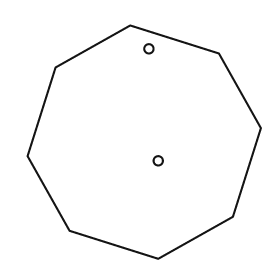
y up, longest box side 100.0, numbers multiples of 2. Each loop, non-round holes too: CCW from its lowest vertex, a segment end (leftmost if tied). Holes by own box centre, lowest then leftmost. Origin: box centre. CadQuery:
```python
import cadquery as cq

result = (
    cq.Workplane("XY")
    .moveTo(6.0, -50.0)
    .lineTo(38.0, -32.0)
    .lineTo(50.0, 6.0)
    .lineTo(32.0, 38.0)
    .lineTo(-6.0, 50.0)
    .lineTo(-38.0, 32.0)
    .lineTo(-50.0, -6.0)
    .lineTo(-32.0, -38.0)
    .close()
    .moveTo(6.0, -8.0)
    .circle(2.0)
    .moveTo(2.0, 40.0)
    .circle(2.0)
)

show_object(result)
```